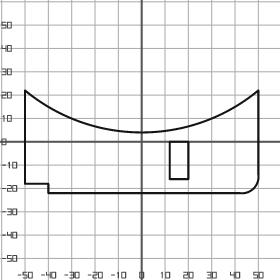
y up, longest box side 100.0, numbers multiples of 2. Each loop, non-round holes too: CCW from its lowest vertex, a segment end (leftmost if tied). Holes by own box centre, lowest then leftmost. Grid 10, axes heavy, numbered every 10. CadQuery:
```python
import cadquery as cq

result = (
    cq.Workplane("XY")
    .moveTo(-40.0, -22.0)
    .lineTo(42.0, -22.0)
    .threePointArc((48.0, -20.0), (50.0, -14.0))
    .lineTo(50.0, 22.0)
    .threePointArc((0.0, 4.0), (-50.0, 22.0))
    .lineTo(-50.0, -18.0)
    .lineTo(-40.0, -18.0)
    .close()
    .moveTo(12.0, -16.0)
    .lineTo(20.0, -16.0)
    .lineTo(20.0, 0.0)
    .lineTo(12.0, 0.0)
    .close()
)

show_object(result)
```